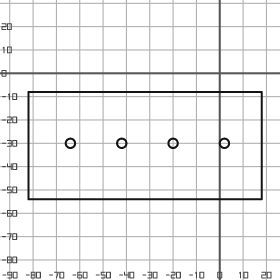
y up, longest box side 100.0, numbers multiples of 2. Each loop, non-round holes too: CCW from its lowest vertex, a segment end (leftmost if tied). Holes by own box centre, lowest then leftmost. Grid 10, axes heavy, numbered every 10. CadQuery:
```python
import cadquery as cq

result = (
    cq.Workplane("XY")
    .moveTo(-82.0, -54.0)
    .lineTo(18.0, -54.0)
    .lineTo(18.0, -8.0)
    .lineTo(-82.0, -8.0)
    .close()
    .moveTo(-64.0, -30.0)
    .circle(2.0)
    .moveTo(-42.0, -30.0)
    .circle(2.0)
    .moveTo(-20.0, -30.0)
    .circle(2.0)
    .moveTo(2.0, -30.0)
    .circle(2.0)
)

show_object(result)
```